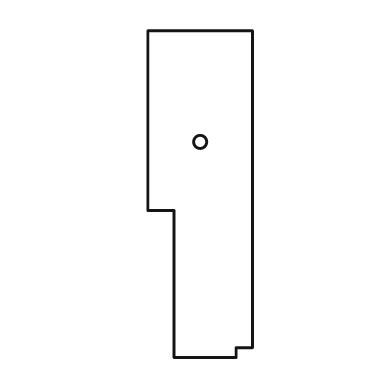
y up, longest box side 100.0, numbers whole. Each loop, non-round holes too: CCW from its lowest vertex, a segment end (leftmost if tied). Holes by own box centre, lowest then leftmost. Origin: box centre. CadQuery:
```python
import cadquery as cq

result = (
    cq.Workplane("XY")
    .moveTo(-8.0, -50.0)
    .lineTo(11.0, -50.0)
    .lineTo(11.0, -47.0)
    .lineTo(16.0, -47.0)
    .lineTo(16.0, 50.0)
    .lineTo(-16.0, 50.0)
    .lineTo(-16.0, -5.0)
    .lineTo(-8.0, -5.0)
    .close()
    .moveTo(0.0, 16.0)
    .circle(2.0)
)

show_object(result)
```